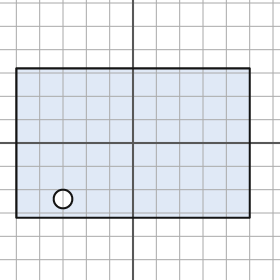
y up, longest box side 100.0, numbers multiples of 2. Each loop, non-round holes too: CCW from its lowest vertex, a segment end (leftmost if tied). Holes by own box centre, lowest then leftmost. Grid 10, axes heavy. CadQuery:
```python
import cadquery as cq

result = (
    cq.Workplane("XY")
    .moveTo(-50.0, -32.0)
    .lineTo(50.0, -32.0)
    .lineTo(50.0, 32.0)
    .lineTo(-50.0, 32.0)
    .close()
    .moveTo(-30.0, -24.0)
    .circle(4.0)
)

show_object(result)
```